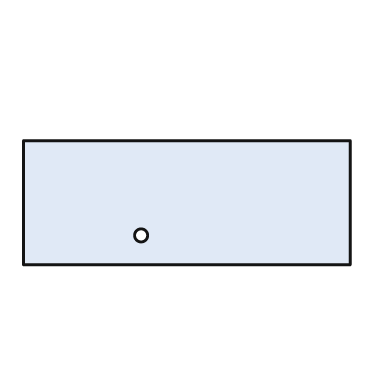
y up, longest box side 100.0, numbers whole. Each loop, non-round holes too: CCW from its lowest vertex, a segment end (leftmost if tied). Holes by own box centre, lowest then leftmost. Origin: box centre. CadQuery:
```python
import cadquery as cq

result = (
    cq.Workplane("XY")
    .moveTo(-50.0, -19.0)
    .lineTo(50.0, -19.0)
    .lineTo(50.0, 19.0)
    .lineTo(-50.0, 19.0)
    .close()
    .moveTo(-14.0, -10.0)
    .circle(2.0)
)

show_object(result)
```